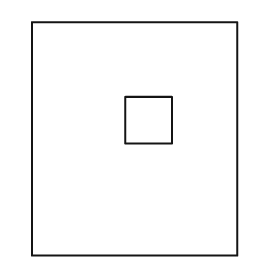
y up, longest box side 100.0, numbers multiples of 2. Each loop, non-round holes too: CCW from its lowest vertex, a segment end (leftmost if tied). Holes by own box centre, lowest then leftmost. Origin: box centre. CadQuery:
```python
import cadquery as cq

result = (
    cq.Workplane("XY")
    .moveTo(-44.0, -50.0)
    .lineTo(44.0, -50.0)
    .lineTo(44.0, 50.0)
    .lineTo(-44.0, 50.0)
    .close()
    .moveTo(-4.0, -2.0)
    .lineTo(16.0, -2.0)
    .lineTo(16.0, 18.0)
    .lineTo(-4.0, 18.0)
    .close()
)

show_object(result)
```